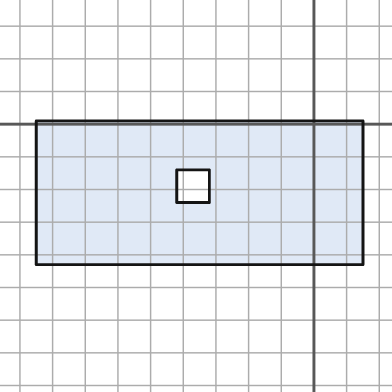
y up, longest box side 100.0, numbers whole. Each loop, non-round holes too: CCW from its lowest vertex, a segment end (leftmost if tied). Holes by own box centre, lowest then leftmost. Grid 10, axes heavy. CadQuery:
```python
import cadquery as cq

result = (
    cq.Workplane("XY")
    .moveTo(-85.0, -43.0)
    .lineTo(15.0, -43.0)
    .lineTo(15.0, 1.0)
    .lineTo(-85.0, 1.0)
    .close()
    .moveTo(-42.0, -24.0)
    .lineTo(-32.0, -24.0)
    .lineTo(-32.0, -14.0)
    .lineTo(-42.0, -14.0)
    .close()
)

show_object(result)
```